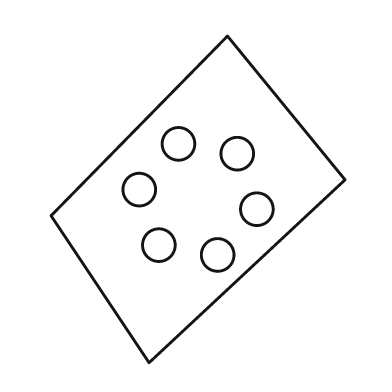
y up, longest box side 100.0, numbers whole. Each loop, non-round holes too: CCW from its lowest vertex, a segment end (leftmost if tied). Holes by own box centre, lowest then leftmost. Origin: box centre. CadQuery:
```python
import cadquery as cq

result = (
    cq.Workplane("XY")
    .moveTo(-15.0, -50.0)
    .lineTo(45.0, 6.0)
    .lineTo(9.0, 50.0)
    .lineTo(-45.0, -5.0)
    .close()
    .moveTo(6.0, -17.0)
    .circle(5.0)
    .moveTo(-12.0, -14.0)
    .circle(5.0)
    .moveTo(18.0, -3.0)
    .circle(5.0)
    .moveTo(-18.0, 3.0)
    .circle(5.0)
    .moveTo(12.0, 14.0)
    .circle(5.0)
    .moveTo(-6.0, 17.0)
    .circle(5.0)
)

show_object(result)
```